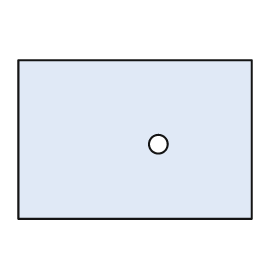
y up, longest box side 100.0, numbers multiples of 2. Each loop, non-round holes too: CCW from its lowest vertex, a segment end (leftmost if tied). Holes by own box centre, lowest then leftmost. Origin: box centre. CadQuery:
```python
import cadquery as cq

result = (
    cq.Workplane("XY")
    .moveTo(-50.0, -34.0)
    .lineTo(50.0, -34.0)
    .lineTo(50.0, 34.0)
    .lineTo(-50.0, 34.0)
    .close()
    .moveTo(10.0, -2.0)
    .circle(4.0)
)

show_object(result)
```